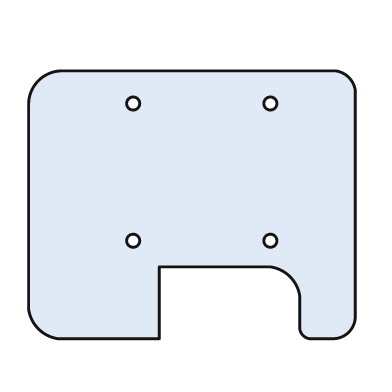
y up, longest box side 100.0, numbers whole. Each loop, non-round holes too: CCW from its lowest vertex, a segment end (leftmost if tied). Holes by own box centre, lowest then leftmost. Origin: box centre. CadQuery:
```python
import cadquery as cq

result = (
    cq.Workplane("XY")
    .moveTo(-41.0, -41.0)
    .lineTo(-10.0, -41.0)
    .lineTo(-10.0, -19.0)
    .lineTo(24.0, -19.0)
    .threePointArc((30.0, -22.0), (33.0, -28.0))
    .lineTo(33.0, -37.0)
    .threePointArc((34.0, -40.0), (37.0, -41.0))
    .lineTo(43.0, -41.0)
    .threePointArc((48.0, -39.0), (50.0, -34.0))
    .lineTo(50.0, 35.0)
    .threePointArc((48.0, 39.0), (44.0, 41.0))
    .lineTo(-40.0, 41.0)
    .threePointArc((-47.0, 38.0), (-50.0, 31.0))
    .lineTo(-50.0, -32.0)
    .threePointArc((-47.0, -38.0), (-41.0, -41.0))
    .close()
    .moveTo(-18.0, -11.0)
    .circle(2.0)
    .moveTo(24.0, -11.0)
    .circle(2.0)
    .moveTo(-18.0, 31.0)
    .circle(2.0)
    .moveTo(24.0, 31.0)
    .circle(2.0)
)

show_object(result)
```